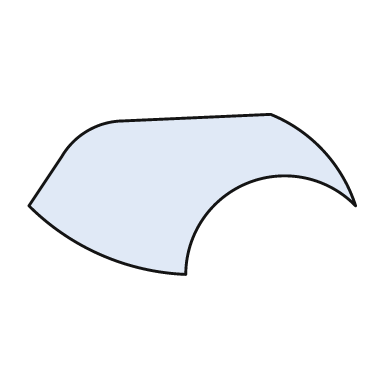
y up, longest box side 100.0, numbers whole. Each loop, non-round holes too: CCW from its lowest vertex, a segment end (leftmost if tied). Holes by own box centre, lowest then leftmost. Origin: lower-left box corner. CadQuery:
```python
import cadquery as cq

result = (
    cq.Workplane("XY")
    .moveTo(48.0, 0.0)
    .threePointArc((67.0, 28.0), (100.0, 21.0))
    .threePointArc((90.0, 38.0), (74.0, 49.0))
    .lineTo(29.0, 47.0)
    .threePointArc((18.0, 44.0), (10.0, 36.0))
    .lineTo(0.0, 21.0)
    .threePointArc((22.0, 6.0), (48.0, 0.0))
    .close()
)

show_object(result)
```